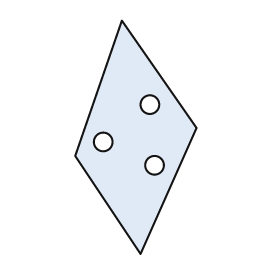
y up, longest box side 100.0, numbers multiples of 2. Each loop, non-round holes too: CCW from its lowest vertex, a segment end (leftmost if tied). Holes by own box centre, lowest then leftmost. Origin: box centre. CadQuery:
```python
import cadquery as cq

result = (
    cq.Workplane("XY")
    .moveTo(2.0, -50.0)
    .lineTo(26.0, 4.0)
    .lineTo(-6.0, 50.0)
    .lineTo(-26.0, -8.0)
    .close()
    .moveTo(8.0, -12.0)
    .circle(4.0)
    .moveTo(-14.0, -2.0)
    .circle(4.0)
    .moveTo(6.0, 14.0)
    .circle(4.0)
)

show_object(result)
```